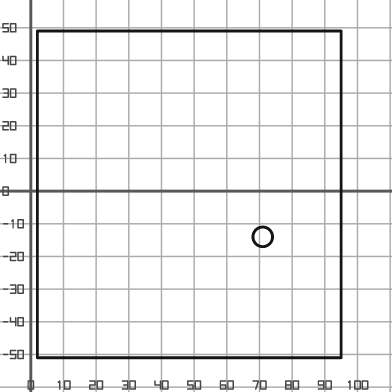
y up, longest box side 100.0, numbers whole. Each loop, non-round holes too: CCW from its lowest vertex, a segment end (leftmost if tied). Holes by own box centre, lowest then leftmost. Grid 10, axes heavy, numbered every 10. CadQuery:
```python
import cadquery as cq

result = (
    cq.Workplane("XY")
    .moveTo(2.0, -51.0)
    .lineTo(95.0, -51.0)
    .lineTo(95.0, 49.0)
    .lineTo(2.0, 49.0)
    .close()
    .moveTo(71.0, -14.0)
    .circle(3.0)
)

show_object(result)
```